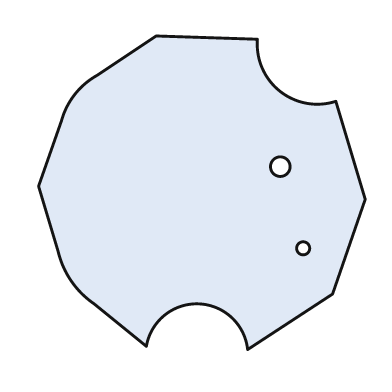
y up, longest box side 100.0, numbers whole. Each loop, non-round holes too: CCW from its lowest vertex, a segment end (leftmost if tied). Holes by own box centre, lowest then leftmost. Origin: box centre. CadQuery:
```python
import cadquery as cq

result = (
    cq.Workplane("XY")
    .moveTo(14.0, -48.0)
    .lineTo(40.0, -31.0)
    .lineTo(50.0, -2.0)
    .lineTo(41.0, 28.0)
    .threePointArc((24.0, 31.0), (17.0, 47.0))
    .lineTo(-14.0, 48.0)
    .lineTo(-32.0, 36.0)
    .threePointArc((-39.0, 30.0), (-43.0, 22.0))
    .lineTo(-50.0, 2.0)
    .lineTo(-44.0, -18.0)
    .threePointArc((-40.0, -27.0), (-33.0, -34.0))
    .lineTo(-17.0, -47.0)
    .threePointArc((-1.0, -34.0), (14.0, -48.0))
    .close()
    .moveTo(31.0, -17.0)
    .circle(2.0)
    .moveTo(24.0, 8.0)
    .circle(3.0)
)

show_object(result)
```